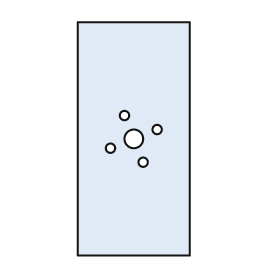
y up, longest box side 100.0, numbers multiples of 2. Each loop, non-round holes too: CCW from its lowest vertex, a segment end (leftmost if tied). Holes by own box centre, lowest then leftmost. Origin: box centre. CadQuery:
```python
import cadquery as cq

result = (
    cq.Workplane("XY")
    .moveTo(-24.0, -50.0)
    .lineTo(24.0, -50.0)
    .lineTo(24.0, 50.0)
    .lineTo(-24.0, 50.0)
    .close()
    .moveTo(4.0, -10.0)
    .circle(2.0)
    .moveTo(-10.0, -4.0)
    .circle(2.0)
    .moveTo(0.0, 0.0)
    .circle(4.0)
    .moveTo(10.0, 4.0)
    .circle(2.0)
    .moveTo(-4.0, 10.0)
    .circle(2.0)
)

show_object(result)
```